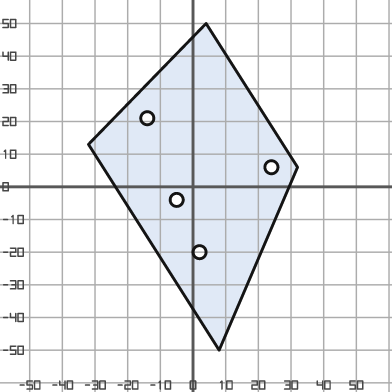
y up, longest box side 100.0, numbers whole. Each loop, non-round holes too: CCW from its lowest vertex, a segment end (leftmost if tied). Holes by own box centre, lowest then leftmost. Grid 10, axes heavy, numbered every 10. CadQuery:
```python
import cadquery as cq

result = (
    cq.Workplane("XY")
    .moveTo(8.0, -50.0)
    .lineTo(32.0, 6.0)
    .lineTo(4.0, 50.0)
    .lineTo(-32.0, 13.0)
    .close()
    .moveTo(2.0, -20.0)
    .circle(2.0)
    .moveTo(-5.0, -4.0)
    .circle(2.0)
    .moveTo(24.0, 6.0)
    .circle(2.0)
    .moveTo(-14.0, 21.0)
    .circle(2.0)
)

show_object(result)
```